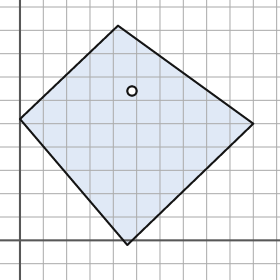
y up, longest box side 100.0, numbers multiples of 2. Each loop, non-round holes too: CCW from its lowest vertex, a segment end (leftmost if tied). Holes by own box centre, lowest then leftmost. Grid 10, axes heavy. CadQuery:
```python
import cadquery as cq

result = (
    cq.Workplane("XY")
    .moveTo(46.0, -2.0)
    .lineTo(100.0, 50.0)
    .lineTo(42.0, 92.0)
    .lineTo(0.0, 52.0)
    .close()
    .moveTo(48.0, 64.0)
    .circle(2.0)
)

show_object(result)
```